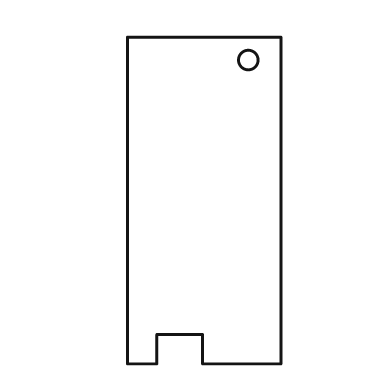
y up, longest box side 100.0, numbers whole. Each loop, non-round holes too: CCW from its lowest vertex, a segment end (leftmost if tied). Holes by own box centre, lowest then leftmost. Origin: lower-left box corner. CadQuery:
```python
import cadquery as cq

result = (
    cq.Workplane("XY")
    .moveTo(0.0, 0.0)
    .lineTo(9.0, 0.0)
    .lineTo(9.0, 9.0)
    .lineTo(23.0, 9.0)
    .lineTo(23.0, 0.0)
    .lineTo(47.0, 0.0)
    .lineTo(47.0, 100.0)
    .lineTo(0.0, 100.0)
    .close()
    .moveTo(37.0, 93.0)
    .circle(3.0)
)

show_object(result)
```